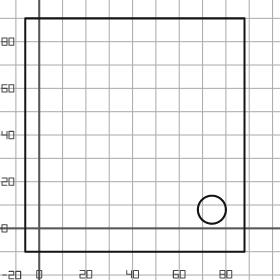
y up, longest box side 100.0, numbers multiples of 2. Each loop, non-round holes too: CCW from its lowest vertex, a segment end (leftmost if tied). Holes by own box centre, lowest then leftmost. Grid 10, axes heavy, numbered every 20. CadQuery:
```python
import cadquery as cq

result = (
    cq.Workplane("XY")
    .moveTo(-6.0, -10.0)
    .lineTo(88.0, -10.0)
    .lineTo(88.0, 90.0)
    .lineTo(-6.0, 90.0)
    .close()
    .moveTo(74.0, 8.0)
    .circle(6.0)
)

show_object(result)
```